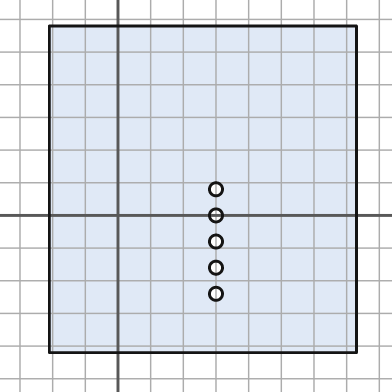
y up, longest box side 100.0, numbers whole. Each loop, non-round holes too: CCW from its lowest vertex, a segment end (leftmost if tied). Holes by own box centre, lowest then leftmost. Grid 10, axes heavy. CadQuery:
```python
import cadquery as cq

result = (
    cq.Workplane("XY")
    .moveTo(-21.0, -42.0)
    .lineTo(73.0, -42.0)
    .lineTo(73.0, 58.0)
    .lineTo(-21.0, 58.0)
    .close()
    .moveTo(30.0, -24.0)
    .circle(2.0)
    .moveTo(30.0, -16.0)
    .circle(2.0)
    .moveTo(30.0, -8.0)
    .circle(2.0)
    .moveTo(30.0, 0.0)
    .circle(2.0)
    .moveTo(30.0, 8.0)
    .circle(2.0)
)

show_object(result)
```